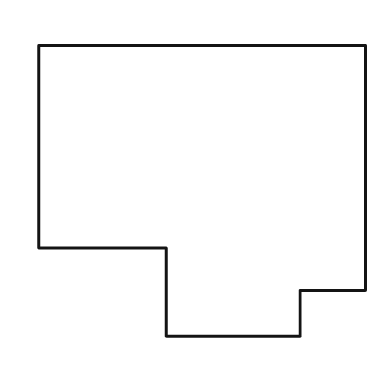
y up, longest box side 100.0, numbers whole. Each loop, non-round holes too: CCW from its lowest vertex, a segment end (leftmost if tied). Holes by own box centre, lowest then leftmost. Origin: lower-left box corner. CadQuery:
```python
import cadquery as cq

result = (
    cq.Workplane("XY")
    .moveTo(39.0, 0.0)
    .lineTo(80.0, 0.0)
    .lineTo(80.0, 14.0)
    .lineTo(100.0, 14.0)
    .lineTo(100.0, 89.0)
    .lineTo(0.0, 89.0)
    .lineTo(0.0, 27.0)
    .lineTo(39.0, 27.0)
    .close()
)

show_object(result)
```